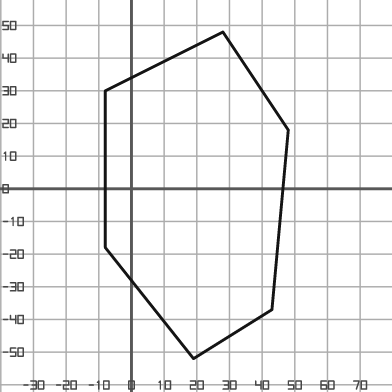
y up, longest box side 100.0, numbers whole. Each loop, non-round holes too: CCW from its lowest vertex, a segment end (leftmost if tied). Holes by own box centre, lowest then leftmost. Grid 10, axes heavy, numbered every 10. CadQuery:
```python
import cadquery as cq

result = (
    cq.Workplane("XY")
    .moveTo(19.0, -52.0)
    .lineTo(43.0, -37.0)
    .lineTo(48.0, 18.0)
    .lineTo(28.0, 48.0)
    .lineTo(-8.0, 30.0)
    .lineTo(-8.0, -18.0)
    .close()
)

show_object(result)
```